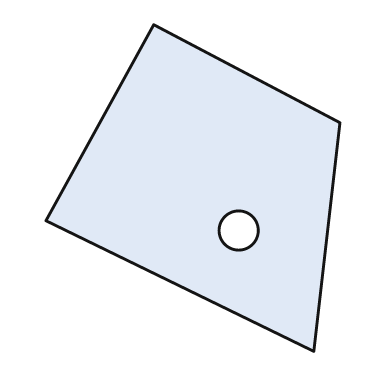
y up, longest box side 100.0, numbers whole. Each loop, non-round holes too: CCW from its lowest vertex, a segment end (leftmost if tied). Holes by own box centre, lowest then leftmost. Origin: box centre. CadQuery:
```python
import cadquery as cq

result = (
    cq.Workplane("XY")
    .moveTo(37.0, -50.0)
    .lineTo(45.0, 20.0)
    .lineTo(-12.0, 50.0)
    .lineTo(-45.0, -10.0)
    .close()
    .moveTo(14.0, -13.0)
    .circle(6.0)
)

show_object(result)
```